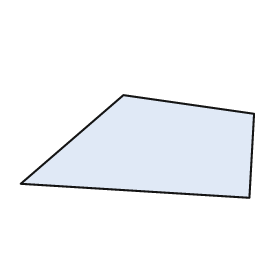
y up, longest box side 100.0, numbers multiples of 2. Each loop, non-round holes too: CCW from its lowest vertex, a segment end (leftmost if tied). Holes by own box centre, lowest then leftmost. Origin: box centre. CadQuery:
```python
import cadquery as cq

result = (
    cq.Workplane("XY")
    .moveTo(48.0, -22.0)
    .lineTo(50.0, 14.0)
    .lineTo(-6.0, 22.0)
    .lineTo(-50.0, -16.0)
    .close()
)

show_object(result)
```